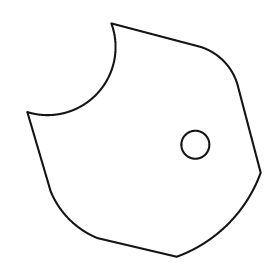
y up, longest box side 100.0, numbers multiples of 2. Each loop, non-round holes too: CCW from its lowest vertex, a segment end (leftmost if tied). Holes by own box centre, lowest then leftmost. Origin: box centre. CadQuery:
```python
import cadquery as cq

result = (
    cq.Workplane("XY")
    .moveTo(14.0, -50.0)
    .threePointArc((36.0, -36.0), (50.0, -14.0))
    .lineTo(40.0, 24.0)
    .threePointArc((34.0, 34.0), (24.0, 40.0))
    .lineTo(-14.0, 50.0)
    .threePointArc((-20.0, 20.0), (-50.0, 12.0))
    .lineTo(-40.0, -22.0)
    .threePointArc((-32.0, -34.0), (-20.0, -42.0))
    .close()
    .moveTo(22.0, -2.0)
    .circle(6.0)
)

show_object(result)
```